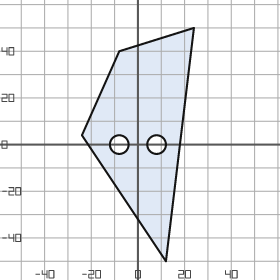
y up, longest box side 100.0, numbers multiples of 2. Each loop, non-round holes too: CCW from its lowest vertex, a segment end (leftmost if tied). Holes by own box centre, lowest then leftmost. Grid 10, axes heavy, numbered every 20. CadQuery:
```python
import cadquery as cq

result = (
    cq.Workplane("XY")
    .moveTo(12.0, -50.0)
    .lineTo(24.0, 50.0)
    .lineTo(-8.0, 40.0)
    .lineTo(-24.0, 4.0)
    .close()
    .moveTo(-8.0, 0.0)
    .circle(4.0)
    .moveTo(8.0, 0.0)
    .circle(4.0)
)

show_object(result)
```